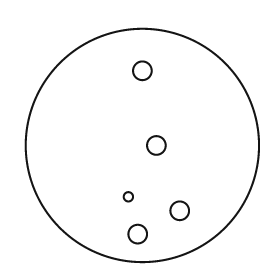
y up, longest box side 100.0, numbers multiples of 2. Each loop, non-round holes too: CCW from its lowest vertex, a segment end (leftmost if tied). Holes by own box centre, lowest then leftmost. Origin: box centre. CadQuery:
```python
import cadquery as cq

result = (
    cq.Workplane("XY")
    .moveTo(0.0, 0.0)
    .circle(50.0)
    .moveTo(-2.0, -38.0)
    .circle(4.0)
    .moveTo(16.0, -28.0)
    .circle(4.0)
    .moveTo(-6.0, -22.0)
    .circle(2.0)
    .moveTo(6.0, 0.0)
    .circle(4.0)
    .moveTo(0.0, 32.0)
    .circle(4.0)
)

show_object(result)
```